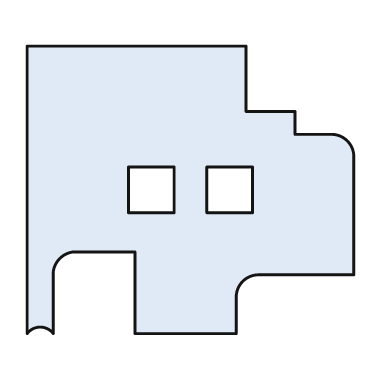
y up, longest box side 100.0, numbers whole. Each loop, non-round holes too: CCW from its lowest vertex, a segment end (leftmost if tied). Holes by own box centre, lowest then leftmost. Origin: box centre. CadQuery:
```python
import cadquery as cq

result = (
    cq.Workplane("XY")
    .moveTo(-50.0, -44.0)
    .threePointArc((-46.0, -42.0), (-42.0, -44.0))
    .lineTo(-42.0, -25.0)
    .threePointArc((-40.0, -21.0), (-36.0, -19.0))
    .lineTo(-17.0, -19.0)
    .lineTo(-17.0, -44.0)
    .lineTo(14.0, -44.0)
    .lineTo(14.0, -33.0)
    .threePointArc((16.0, -28.0), (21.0, -26.0))
    .lineTo(50.0, -26.0)
    .lineTo(50.0, 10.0)
    .threePointArc((48.0, 15.0), (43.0, 17.0))
    .lineTo(32.0, 17.0)
    .lineTo(32.0, 24.0)
    .lineTo(17.0, 24.0)
    .lineTo(17.0, 44.0)
    .lineTo(-50.0, 44.0)
    .close()
    .moveTo(-19.0, -7.0)
    .lineTo(-5.0, -7.0)
    .lineTo(-5.0, 7.0)
    .lineTo(-19.0, 7.0)
    .close()
    .moveTo(5.0, -7.0)
    .lineTo(19.0, -7.0)
    .lineTo(19.0, 7.0)
    .lineTo(5.0, 7.0)
    .close()
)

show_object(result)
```